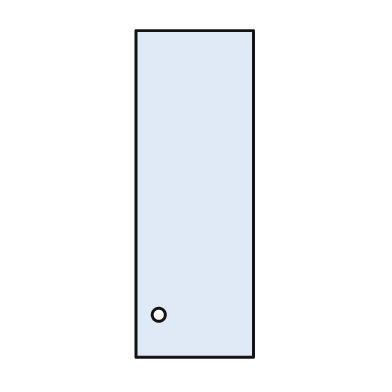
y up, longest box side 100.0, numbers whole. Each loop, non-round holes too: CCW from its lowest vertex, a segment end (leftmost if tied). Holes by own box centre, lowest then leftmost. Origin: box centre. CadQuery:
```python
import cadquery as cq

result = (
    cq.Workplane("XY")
    .moveTo(-18.0, -50.0)
    .lineTo(18.0, -50.0)
    .lineTo(18.0, 50.0)
    .lineTo(-18.0, 50.0)
    .close()
    .moveTo(-11.0, -37.0)
    .circle(2.0)
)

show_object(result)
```